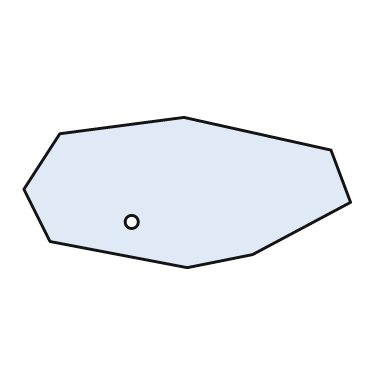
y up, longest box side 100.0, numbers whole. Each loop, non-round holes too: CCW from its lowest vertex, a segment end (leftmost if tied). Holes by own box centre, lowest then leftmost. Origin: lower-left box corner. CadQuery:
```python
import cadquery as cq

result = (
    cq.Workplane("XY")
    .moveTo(50.0, 0.0)
    .lineTo(70.0, 4.0)
    .lineTo(100.0, 20.0)
    .lineTo(94.0, 36.0)
    .lineTo(49.0, 46.0)
    .lineTo(11.0, 41.0)
    .lineTo(0.0, 24.0)
    .lineTo(8.0, 8.0)
    .close()
    .moveTo(33.0, 14.0)
    .circle(2.0)
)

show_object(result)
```